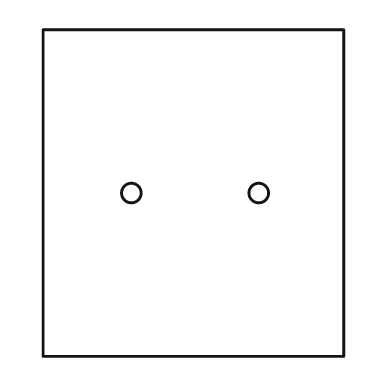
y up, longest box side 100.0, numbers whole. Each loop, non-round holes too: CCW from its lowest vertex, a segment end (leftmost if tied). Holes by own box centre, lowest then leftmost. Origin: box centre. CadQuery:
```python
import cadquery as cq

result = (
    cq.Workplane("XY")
    .moveTo(-46.0, -50.0)
    .lineTo(46.0, -50.0)
    .lineTo(46.0, 50.0)
    .lineTo(-46.0, 50.0)
    .close()
    .moveTo(-19.0, 0.0)
    .circle(3.0)
    .moveTo(20.0, 0.0)
    .circle(3.0)
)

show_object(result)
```